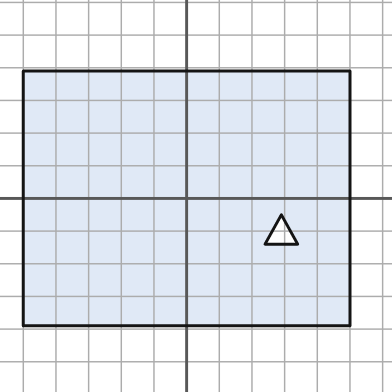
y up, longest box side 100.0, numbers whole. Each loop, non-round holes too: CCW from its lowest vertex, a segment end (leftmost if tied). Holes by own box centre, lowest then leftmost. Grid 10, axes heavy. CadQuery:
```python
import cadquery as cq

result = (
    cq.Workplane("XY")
    .moveTo(-50.0, -39.0)
    .lineTo(50.0, -39.0)
    .lineTo(50.0, 39.0)
    .lineTo(-50.0, 39.0)
    .close()
    .moveTo(24.0, -14.0)
    .lineTo(34.0, -14.0)
    .lineTo(29.0, -5.0)
    .close()
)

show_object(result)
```